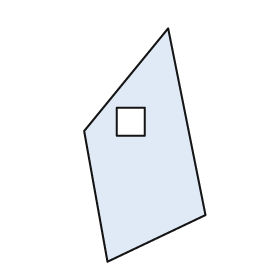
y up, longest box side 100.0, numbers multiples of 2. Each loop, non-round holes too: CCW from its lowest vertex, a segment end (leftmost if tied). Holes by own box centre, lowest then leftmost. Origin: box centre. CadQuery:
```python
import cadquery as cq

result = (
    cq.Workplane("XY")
    .moveTo(-16.0, -50.0)
    .lineTo(26.0, -30.0)
    .lineTo(10.0, 50.0)
    .lineTo(-26.0, 6.0)
    .close()
    .moveTo(-12.0, 4.0)
    .lineTo(0.0, 4.0)
    .lineTo(0.0, 16.0)
    .lineTo(-12.0, 16.0)
    .close()
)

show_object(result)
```